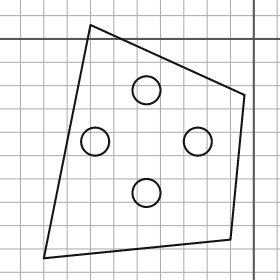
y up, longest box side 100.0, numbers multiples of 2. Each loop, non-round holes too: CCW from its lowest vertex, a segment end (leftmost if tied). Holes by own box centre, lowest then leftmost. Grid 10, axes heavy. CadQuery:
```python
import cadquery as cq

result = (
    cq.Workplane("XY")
    .moveTo(-90.0, -94.0)
    .lineTo(-10.0, -86.0)
    .lineTo(-4.0, -24.0)
    .lineTo(-70.0, 6.0)
    .close()
    .moveTo(-46.0, -66.0)
    .circle(6.0)
    .moveTo(-68.0, -44.0)
    .circle(6.0)
    .moveTo(-24.0, -44.0)
    .circle(6.0)
    .moveTo(-46.0, -22.0)
    .circle(6.0)
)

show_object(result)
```